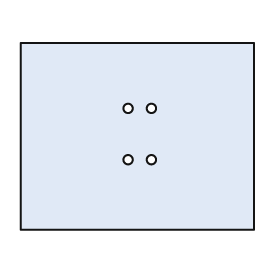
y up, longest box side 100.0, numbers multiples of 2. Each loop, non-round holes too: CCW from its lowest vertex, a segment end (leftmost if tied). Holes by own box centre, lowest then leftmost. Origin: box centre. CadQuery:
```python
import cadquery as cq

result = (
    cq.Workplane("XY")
    .moveTo(-50.0, -40.0)
    .lineTo(50.0, -40.0)
    .lineTo(50.0, 40.0)
    .lineTo(-50.0, 40.0)
    .close()
    .moveTo(-4.0, -10.0)
    .circle(2.0)
    .moveTo(6.0, -10.0)
    .circle(2.0)
    .moveTo(-4.0, 12.0)
    .circle(2.0)
    .moveTo(6.0, 12.0)
    .circle(2.0)
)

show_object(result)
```